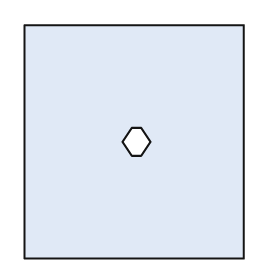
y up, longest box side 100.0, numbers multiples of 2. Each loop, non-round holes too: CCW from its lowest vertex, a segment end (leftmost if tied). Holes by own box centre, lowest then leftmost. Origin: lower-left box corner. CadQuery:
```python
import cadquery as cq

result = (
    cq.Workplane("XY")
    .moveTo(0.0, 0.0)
    .lineTo(94.0, 0.0)
    .lineTo(94.0, 100.0)
    .lineTo(0.0, 100.0)
    .close()
    .moveTo(46.0, 44.0)
    .lineTo(50.0, 44.0)
    .lineTo(54.0, 50.0)
    .lineTo(50.0, 56.0)
    .lineTo(46.0, 56.0)
    .lineTo(42.0, 50.0)
    .close()
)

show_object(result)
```